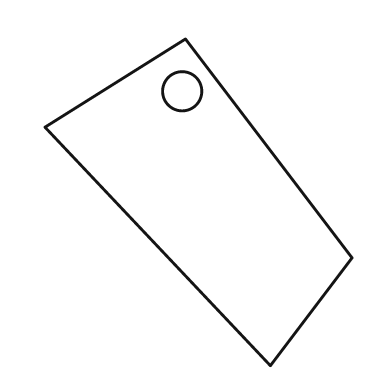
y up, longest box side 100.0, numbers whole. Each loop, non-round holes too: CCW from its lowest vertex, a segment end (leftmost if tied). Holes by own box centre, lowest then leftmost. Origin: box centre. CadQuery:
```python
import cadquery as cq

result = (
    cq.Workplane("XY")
    .moveTo(22.0, -50.0)
    .lineTo(47.0, -17.0)
    .lineTo(-4.0, 50.0)
    .lineTo(-47.0, 23.0)
    .close()
    .moveTo(-5.0, 34.0)
    .circle(6.0)
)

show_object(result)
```